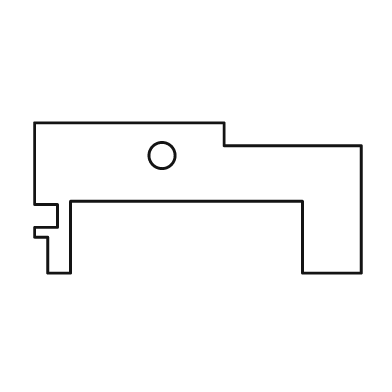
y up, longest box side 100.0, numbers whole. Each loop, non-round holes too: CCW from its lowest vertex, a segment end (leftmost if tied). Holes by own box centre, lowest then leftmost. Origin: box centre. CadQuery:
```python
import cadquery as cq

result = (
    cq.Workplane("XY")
    .moveTo(-46.0, -23.0)
    .lineTo(-39.0, -23.0)
    .lineTo(-39.0, -1.0)
    .lineTo(32.0, -1.0)
    .lineTo(32.0, -23.0)
    .lineTo(50.0, -23.0)
    .lineTo(50.0, 16.0)
    .lineTo(8.0, 16.0)
    .lineTo(8.0, 23.0)
    .lineTo(-50.0, 23.0)
    .lineTo(-50.0, -2.0)
    .lineTo(-43.0, -2.0)
    .lineTo(-43.0, -9.0)
    .lineTo(-50.0, -9.0)
    .lineTo(-50.0, -12.0)
    .lineTo(-46.0, -12.0)
    .close()
    .moveTo(-11.0, 13.0)
    .circle(4.0)
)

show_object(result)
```